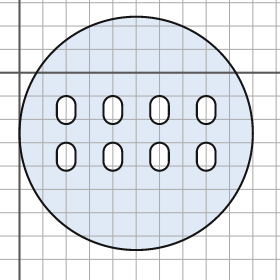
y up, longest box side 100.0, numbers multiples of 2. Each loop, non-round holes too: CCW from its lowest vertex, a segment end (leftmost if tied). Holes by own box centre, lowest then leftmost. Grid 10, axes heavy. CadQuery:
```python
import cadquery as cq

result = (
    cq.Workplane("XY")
    .moveTo(50.0, -26.0)
    .circle(50.0)
    .moveTo(16.0, -38.0)
    .threePointArc((20.0, -42.0), (24.0, -38.0))
    .lineTo(24.0, -34.0)
    .threePointArc((20.0, -30.0), (16.0, -34.0))
    .close()
    .moveTo(36.0, -38.0)
    .threePointArc((40.0, -42.0), (44.0, -38.0))
    .lineTo(44.0, -34.0)
    .threePointArc((40.0, -30.0), (36.0, -34.0))
    .close()
    .moveTo(56.0, -38.0)
    .threePointArc((60.0, -42.0), (64.0, -38.0))
    .lineTo(64.0, -34.0)
    .threePointArc((60.0, -30.0), (56.0, -34.0))
    .close()
    .moveTo(76.0, -38.0)
    .threePointArc((80.0, -42.0), (84.0, -38.0))
    .lineTo(84.0, -34.0)
    .threePointArc((80.0, -30.0), (76.0, -34.0))
    .close()
    .moveTo(16.0, -18.0)
    .threePointArc((20.0, -22.0), (24.0, -18.0))
    .lineTo(24.0, -14.0)
    .threePointArc((20.0, -10.0), (16.0, -14.0))
    .close()
    .moveTo(36.0, -18.0)
    .threePointArc((40.0, -22.0), (44.0, -18.0))
    .lineTo(44.0, -14.0)
    .threePointArc((40.0, -10.0), (36.0, -14.0))
    .close()
    .moveTo(56.0, -18.0)
    .threePointArc((60.0, -22.0), (64.0, -18.0))
    .lineTo(64.0, -14.0)
    .threePointArc((60.0, -10.0), (56.0, -14.0))
    .close()
    .moveTo(76.0, -18.0)
    .threePointArc((80.0, -22.0), (84.0, -18.0))
    .lineTo(84.0, -14.0)
    .threePointArc((80.0, -10.0), (76.0, -14.0))
    .close()
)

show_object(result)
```